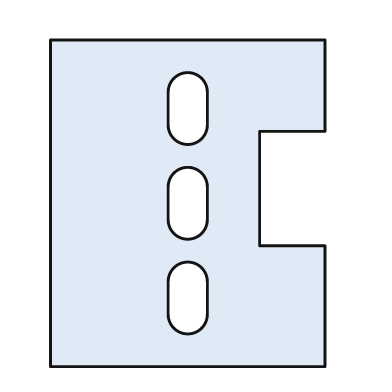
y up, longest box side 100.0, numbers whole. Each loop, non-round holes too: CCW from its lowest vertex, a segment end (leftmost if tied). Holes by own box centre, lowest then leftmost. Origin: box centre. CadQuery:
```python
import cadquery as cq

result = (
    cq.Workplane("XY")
    .moveTo(-42.0, -50.0)
    .lineTo(42.0, -50.0)
    .lineTo(42.0, -13.0)
    .lineTo(22.0, -13.0)
    .lineTo(22.0, 22.0)
    .lineTo(42.0, 22.0)
    .lineTo(42.0, 50.0)
    .lineTo(-42.0, 50.0)
    .close()
    .moveTo(-6.0, -34.0)
    .threePointArc((0.0, -40.0), (6.0, -34.0))
    .lineTo(6.0, -24.0)
    .threePointArc((0.0, -18.0), (-6.0, -24.0))
    .close()
    .moveTo(-6.0, -5.0)
    .threePointArc((0.0, -11.0), (6.0, -5.0))
    .lineTo(6.0, 5.0)
    .threePointArc((0.0, 11.0), (-6.0, 5.0))
    .close()
    .moveTo(-6.0, 24.0)
    .threePointArc((0.0, 18.0), (6.0, 24.0))
    .lineTo(6.0, 34.0)
    .threePointArc((0.0, 40.0), (-6.0, 34.0))
    .close()
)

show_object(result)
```